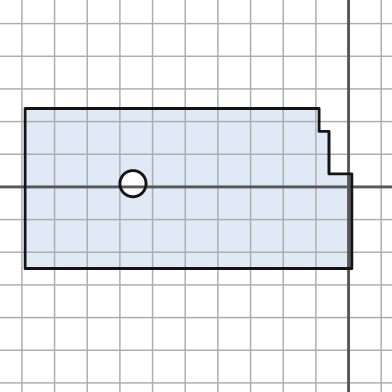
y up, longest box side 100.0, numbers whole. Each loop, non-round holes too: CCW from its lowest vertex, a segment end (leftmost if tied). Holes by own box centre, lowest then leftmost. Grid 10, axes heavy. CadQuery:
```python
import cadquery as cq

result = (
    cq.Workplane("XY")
    .moveTo(-99.0, -25.0)
    .lineTo(1.0, -25.0)
    .lineTo(1.0, 4.0)
    .lineTo(-6.0, 4.0)
    .lineTo(-6.0, 17.0)
    .lineTo(-9.0, 17.0)
    .lineTo(-9.0, 24.0)
    .lineTo(-99.0, 24.0)
    .close()
    .moveTo(-66.0, 1.0)
    .circle(4.0)
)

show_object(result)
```